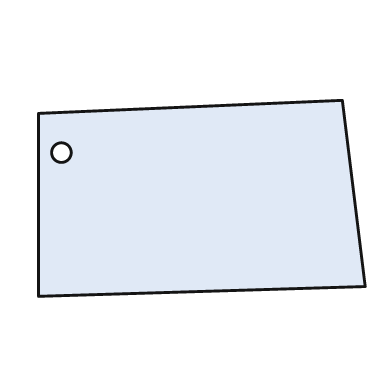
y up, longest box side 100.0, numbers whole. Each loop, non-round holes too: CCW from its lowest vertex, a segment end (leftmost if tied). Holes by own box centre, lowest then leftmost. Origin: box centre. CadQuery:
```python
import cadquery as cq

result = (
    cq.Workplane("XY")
    .moveTo(-50.0, -30.0)
    .lineTo(50.0, -27.0)
    .lineTo(43.0, 30.0)
    .lineTo(-50.0, 26.0)
    .close()
    .moveTo(-43.0, 14.0)
    .circle(3.0)
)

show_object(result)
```